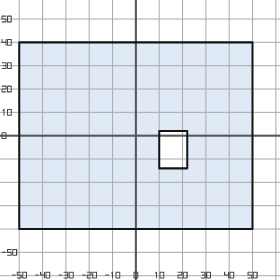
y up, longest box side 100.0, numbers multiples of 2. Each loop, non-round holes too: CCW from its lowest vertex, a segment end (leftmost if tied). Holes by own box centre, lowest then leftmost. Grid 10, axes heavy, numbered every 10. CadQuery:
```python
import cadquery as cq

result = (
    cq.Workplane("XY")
    .moveTo(-50.0, -40.0)
    .lineTo(50.0, -40.0)
    .lineTo(50.0, 40.0)
    .lineTo(-50.0, 40.0)
    .close()
    .moveTo(10.0, -14.0)
    .lineTo(22.0, -14.0)
    .lineTo(22.0, 2.0)
    .lineTo(10.0, 2.0)
    .close()
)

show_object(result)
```